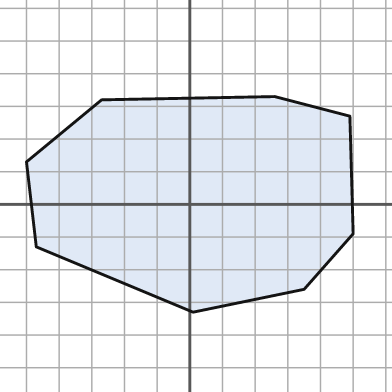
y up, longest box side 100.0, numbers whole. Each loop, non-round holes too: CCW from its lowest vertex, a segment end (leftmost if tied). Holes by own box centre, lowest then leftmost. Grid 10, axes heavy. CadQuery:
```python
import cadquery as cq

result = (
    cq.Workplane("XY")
    .moveTo(1.0, -33.0)
    .lineTo(35.0, -26.0)
    .lineTo(50.0, -9.0)
    .lineTo(49.0, 27.0)
    .lineTo(26.0, 33.0)
    .lineTo(-27.0, 32.0)
    .lineTo(-50.0, 13.0)
    .lineTo(-47.0, -13.0)
    .close()
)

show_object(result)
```